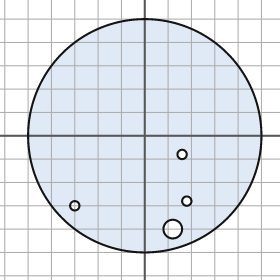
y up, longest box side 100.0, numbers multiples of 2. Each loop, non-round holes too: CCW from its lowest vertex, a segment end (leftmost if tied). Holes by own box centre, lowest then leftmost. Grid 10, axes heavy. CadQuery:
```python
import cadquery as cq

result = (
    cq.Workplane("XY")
    .moveTo(0.0, 0.0)
    .circle(50.0)
    .moveTo(12.0, -40.0)
    .circle(4.0)
    .moveTo(-30.0, -30.0)
    .circle(2.0)
    .moveTo(18.0, -28.0)
    .circle(2.0)
    .moveTo(16.0, -8.0)
    .circle(2.0)
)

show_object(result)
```